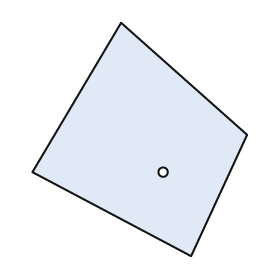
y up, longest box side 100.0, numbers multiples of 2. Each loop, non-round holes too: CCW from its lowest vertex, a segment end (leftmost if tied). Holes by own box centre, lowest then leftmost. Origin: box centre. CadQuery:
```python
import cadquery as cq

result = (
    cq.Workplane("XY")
    .moveTo(22.0, -50.0)
    .lineTo(46.0, 2.0)
    .lineTo(-8.0, 50.0)
    .lineTo(-46.0, -14.0)
    .close()
    .moveTo(10.0, -14.0)
    .circle(2.0)
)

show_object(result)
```